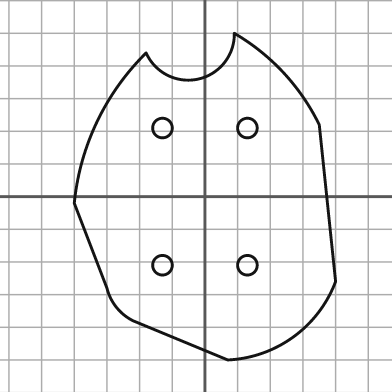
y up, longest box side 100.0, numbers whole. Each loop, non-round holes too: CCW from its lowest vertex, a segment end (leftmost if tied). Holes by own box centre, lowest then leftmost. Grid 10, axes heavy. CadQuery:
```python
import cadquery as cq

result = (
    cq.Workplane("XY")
    .moveTo(7.0, -50.0)
    .threePointArc((27.0, -43.0), (40.0, -26.0))
    .lineTo(35.0, 22.0)
    .threePointArc((24.0, 38.0), (9.0, 50.0))
    .threePointArc((-2.0, 36.0), (-18.0, 44.0))
    .threePointArc((-33.0, 23.0), (-40.0, -2.0))
    .lineTo(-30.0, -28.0)
    .threePointArc((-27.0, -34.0), (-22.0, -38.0))
    .close()
    .moveTo(-13.0, -21.0)
    .circle(3.0)
    .moveTo(13.0, -21.0)
    .circle(3.0)
    .moveTo(-13.0, 21.0)
    .circle(3.0)
    .moveTo(13.0, 21.0)
    .circle(3.0)
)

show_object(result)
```